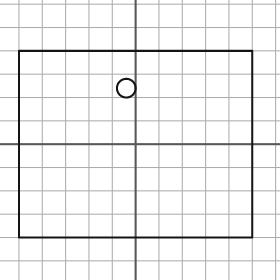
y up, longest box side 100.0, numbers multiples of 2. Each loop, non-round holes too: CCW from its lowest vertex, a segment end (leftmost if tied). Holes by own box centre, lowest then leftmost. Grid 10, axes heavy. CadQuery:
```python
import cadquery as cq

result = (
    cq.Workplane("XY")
    .moveTo(-50.0, -40.0)
    .lineTo(50.0, -40.0)
    .lineTo(50.0, 40.0)
    .lineTo(-50.0, 40.0)
    .close()
    .moveTo(-4.0, 24.0)
    .circle(4.0)
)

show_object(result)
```